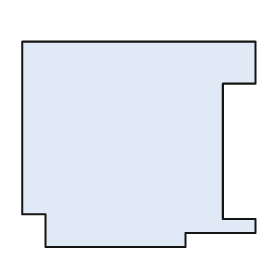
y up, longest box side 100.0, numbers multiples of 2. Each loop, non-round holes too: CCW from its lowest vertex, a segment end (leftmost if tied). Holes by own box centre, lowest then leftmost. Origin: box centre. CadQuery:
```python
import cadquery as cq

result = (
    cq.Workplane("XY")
    .moveTo(-40.0, -44.0)
    .lineTo(20.0, -44.0)
    .lineTo(20.0, -38.0)
    .lineTo(50.0, -38.0)
    .lineTo(50.0, -32.0)
    .lineTo(36.0, -32.0)
    .lineTo(36.0, 26.0)
    .lineTo(50.0, 26.0)
    .lineTo(50.0, 44.0)
    .lineTo(-50.0, 44.0)
    .lineTo(-50.0, -30.0)
    .lineTo(-40.0, -30.0)
    .close()
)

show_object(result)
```